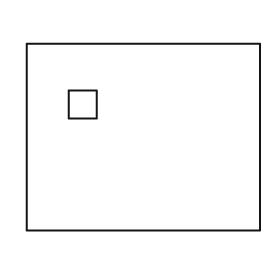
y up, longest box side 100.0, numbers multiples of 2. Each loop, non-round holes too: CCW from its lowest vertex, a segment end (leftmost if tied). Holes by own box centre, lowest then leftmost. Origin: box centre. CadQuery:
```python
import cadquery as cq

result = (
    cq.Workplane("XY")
    .moveTo(-50.0, -40.0)
    .lineTo(50.0, -40.0)
    .lineTo(50.0, 40.0)
    .lineTo(-50.0, 40.0)
    .close()
    .moveTo(-32.0, 8.0)
    .lineTo(-20.0, 8.0)
    .lineTo(-20.0, 20.0)
    .lineTo(-32.0, 20.0)
    .close()
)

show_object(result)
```